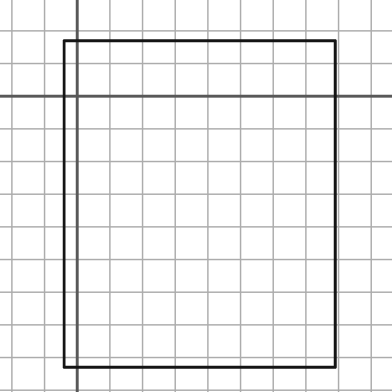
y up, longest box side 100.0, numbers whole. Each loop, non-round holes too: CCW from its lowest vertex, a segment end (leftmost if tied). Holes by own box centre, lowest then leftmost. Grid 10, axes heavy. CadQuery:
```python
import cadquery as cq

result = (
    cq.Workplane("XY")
    .moveTo(-4.0, -83.0)
    .lineTo(79.0, -83.0)
    .lineTo(79.0, 17.0)
    .lineTo(-4.0, 17.0)
    .close()
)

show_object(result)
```